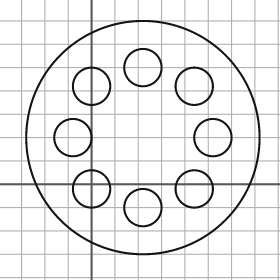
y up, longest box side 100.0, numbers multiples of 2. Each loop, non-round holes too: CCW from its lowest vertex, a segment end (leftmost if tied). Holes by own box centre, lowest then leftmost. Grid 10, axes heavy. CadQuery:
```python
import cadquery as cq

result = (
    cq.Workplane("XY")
    .moveTo(22.0, 20.0)
    .circle(50.0)
    .moveTo(22.0, -10.0)
    .circle(8.0)
    .moveTo(0.0, -2.0)
    .circle(8.0)
    .moveTo(44.0, -2.0)
    .circle(8.0)
    .moveTo(-8.0, 20.0)
    .circle(8.0)
    .moveTo(52.0, 20.0)
    .circle(8.0)
    .moveTo(0.0, 42.0)
    .circle(8.0)
    .moveTo(44.0, 42.0)
    .circle(8.0)
    .moveTo(22.0, 50.0)
    .circle(8.0)
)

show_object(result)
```